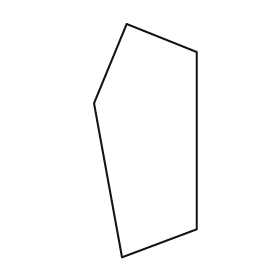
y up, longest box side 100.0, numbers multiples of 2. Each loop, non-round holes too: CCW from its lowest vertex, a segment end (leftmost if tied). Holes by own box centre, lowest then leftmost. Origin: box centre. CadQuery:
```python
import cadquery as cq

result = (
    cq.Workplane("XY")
    .moveTo(-10.0, -50.0)
    .lineTo(22.0, -38.0)
    .lineTo(22.0, 38.0)
    .lineTo(-8.0, 50.0)
    .lineTo(-22.0, 16.0)
    .close()
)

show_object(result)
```